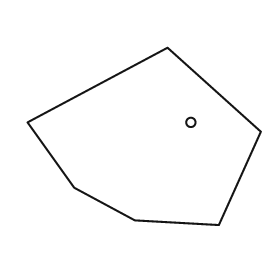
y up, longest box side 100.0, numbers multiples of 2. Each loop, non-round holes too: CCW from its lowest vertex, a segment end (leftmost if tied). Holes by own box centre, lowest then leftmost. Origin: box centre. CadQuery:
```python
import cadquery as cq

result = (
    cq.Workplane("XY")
    .moveTo(32.0, -38.0)
    .lineTo(50.0, 2.0)
    .lineTo(10.0, 38.0)
    .lineTo(-50.0, 6.0)
    .lineTo(-30.0, -22.0)
    .lineTo(-4.0, -36.0)
    .close()
    .moveTo(20.0, 6.0)
    .circle(2.0)
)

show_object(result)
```